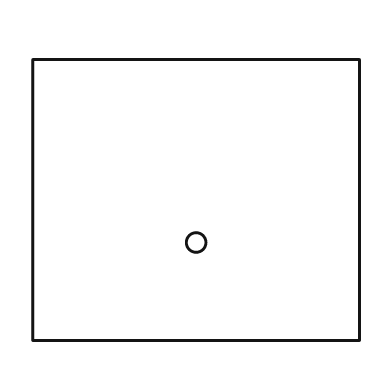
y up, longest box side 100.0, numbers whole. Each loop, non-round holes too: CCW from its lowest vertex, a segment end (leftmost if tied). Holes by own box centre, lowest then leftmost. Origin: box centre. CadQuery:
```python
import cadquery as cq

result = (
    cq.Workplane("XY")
    .moveTo(-50.0, -43.0)
    .lineTo(50.0, -43.0)
    .lineTo(50.0, 43.0)
    .lineTo(-50.0, 43.0)
    .close()
    .moveTo(0.0, -13.0)
    .circle(3.0)
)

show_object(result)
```